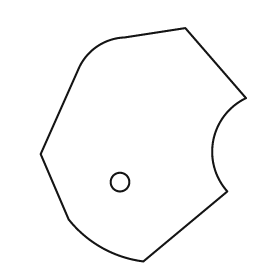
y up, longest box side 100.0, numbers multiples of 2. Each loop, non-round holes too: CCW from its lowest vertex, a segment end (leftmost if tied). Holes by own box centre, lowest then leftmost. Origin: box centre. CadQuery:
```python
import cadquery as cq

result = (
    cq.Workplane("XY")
    .moveTo(0.0, -50.0)
    .lineTo(36.0, -20.0)
    .threePointArc((30.0, 2.0), (44.0, 20.0))
    .lineTo(18.0, 50.0)
    .lineTo(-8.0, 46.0)
    .threePointArc((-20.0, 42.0), (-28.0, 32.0))
    .lineTo(-44.0, -4.0)
    .lineTo(-32.0, -32.0)
    .threePointArc((-18.0, -44.0), (0.0, -50.0))
    .close()
    .moveTo(-10.0, -16.0)
    .circle(4.0)
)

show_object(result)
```